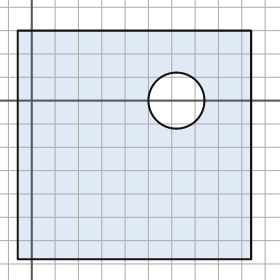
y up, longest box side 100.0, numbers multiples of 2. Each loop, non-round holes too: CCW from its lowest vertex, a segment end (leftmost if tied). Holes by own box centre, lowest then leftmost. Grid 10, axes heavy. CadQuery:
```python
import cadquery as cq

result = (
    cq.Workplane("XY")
    .moveTo(-6.0, -68.0)
    .lineTo(94.0, -68.0)
    .lineTo(94.0, 30.0)
    .lineTo(-6.0, 30.0)
    .close()
    .moveTo(62.0, 0.0)
    .circle(12.0)
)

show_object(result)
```